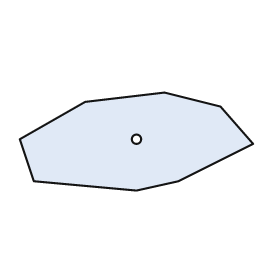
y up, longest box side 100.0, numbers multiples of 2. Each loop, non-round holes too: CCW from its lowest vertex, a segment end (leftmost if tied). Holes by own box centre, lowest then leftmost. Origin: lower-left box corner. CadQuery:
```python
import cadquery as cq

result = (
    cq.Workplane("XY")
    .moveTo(50.0, 0.0)
    .lineTo(68.0, 4.0)
    .lineTo(100.0, 20.0)
    .lineTo(86.0, 36.0)
    .lineTo(62.0, 42.0)
    .lineTo(28.0, 38.0)
    .lineTo(0.0, 22.0)
    .lineTo(6.0, 4.0)
    .close()
    .moveTo(50.0, 22.0)
    .circle(2.0)
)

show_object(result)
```